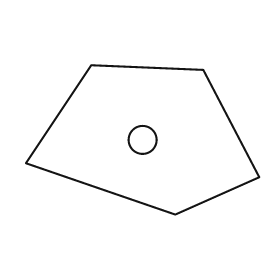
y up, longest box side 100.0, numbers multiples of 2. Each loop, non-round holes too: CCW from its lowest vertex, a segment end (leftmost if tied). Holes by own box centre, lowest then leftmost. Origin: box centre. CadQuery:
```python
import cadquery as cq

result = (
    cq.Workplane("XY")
    .moveTo(14.0, -32.0)
    .lineTo(50.0, -16.0)
    .lineTo(26.0, 30.0)
    .lineTo(-22.0, 32.0)
    .lineTo(-50.0, -10.0)
    .close()
    .moveTo(0.0, 0.0)
    .circle(6.0)
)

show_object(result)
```